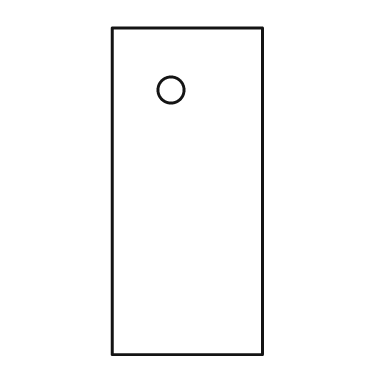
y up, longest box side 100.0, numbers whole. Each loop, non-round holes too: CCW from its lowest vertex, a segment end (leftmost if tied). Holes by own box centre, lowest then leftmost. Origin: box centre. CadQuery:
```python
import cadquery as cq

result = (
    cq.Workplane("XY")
    .moveTo(-23.0, -50.0)
    .lineTo(23.0, -50.0)
    .lineTo(23.0, 50.0)
    .lineTo(-23.0, 50.0)
    .close()
    .moveTo(-5.0, 31.0)
    .circle(4.0)
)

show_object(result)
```